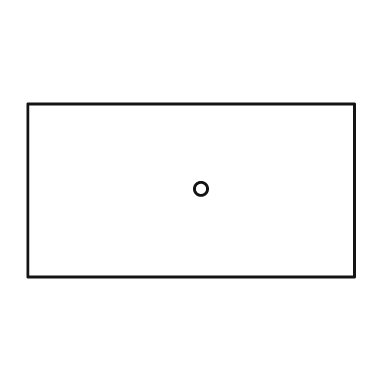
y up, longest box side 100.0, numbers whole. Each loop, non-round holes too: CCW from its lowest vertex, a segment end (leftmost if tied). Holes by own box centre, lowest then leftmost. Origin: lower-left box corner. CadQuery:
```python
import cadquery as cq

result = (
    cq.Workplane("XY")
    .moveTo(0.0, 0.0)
    .lineTo(100.0, 0.0)
    .lineTo(100.0, 53.0)
    .lineTo(0.0, 53.0)
    .close()
    .moveTo(53.0, 27.0)
    .circle(2.0)
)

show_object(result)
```